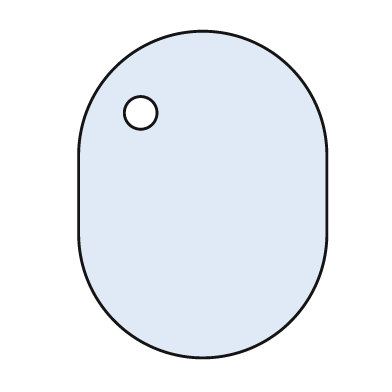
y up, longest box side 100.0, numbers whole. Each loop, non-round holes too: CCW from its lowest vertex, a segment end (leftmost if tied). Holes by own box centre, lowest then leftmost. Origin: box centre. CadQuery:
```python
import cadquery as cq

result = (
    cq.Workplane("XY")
    .moveTo(-38.0, -12.0)
    .threePointArc((0.0, -50.0), (38.0, -12.0))
    .lineTo(38.0, 12.0)
    .threePointArc((0.0, 50.0), (-38.0, 12.0))
    .close()
    .moveTo(-19.0, 25.0)
    .circle(5.0)
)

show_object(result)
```